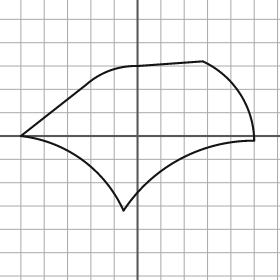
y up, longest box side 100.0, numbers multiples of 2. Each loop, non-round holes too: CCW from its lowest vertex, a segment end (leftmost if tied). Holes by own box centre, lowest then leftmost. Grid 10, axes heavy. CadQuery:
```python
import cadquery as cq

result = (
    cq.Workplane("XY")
    .moveTo(-6.0, -32.0)
    .threePointArc((18.0, -10.0), (50.0, -2.0))
    .threePointArc((44.0, 18.0), (28.0, 32.0))
    .lineTo(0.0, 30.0)
    .threePointArc((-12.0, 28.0), (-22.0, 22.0))
    .lineTo(-50.0, 0.0)
    .threePointArc((-24.0, -10.0), (-6.0, -32.0))
    .close()
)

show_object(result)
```